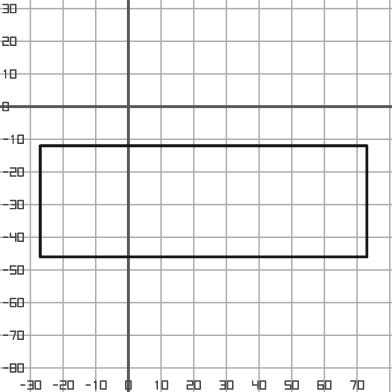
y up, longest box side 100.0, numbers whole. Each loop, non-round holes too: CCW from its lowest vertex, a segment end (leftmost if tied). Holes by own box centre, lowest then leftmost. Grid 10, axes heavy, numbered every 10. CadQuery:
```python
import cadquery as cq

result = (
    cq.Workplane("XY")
    .moveTo(-27.0, -46.0)
    .lineTo(73.0, -46.0)
    .lineTo(73.0, -12.0)
    .lineTo(-27.0, -12.0)
    .close()
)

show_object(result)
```